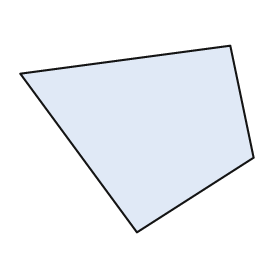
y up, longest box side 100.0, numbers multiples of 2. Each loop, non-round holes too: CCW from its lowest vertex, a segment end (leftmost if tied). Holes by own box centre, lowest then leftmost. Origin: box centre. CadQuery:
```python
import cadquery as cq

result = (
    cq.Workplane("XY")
    .moveTo(0.0, -40.0)
    .lineTo(50.0, -8.0)
    .lineTo(40.0, 40.0)
    .lineTo(-50.0, 28.0)
    .close()
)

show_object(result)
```